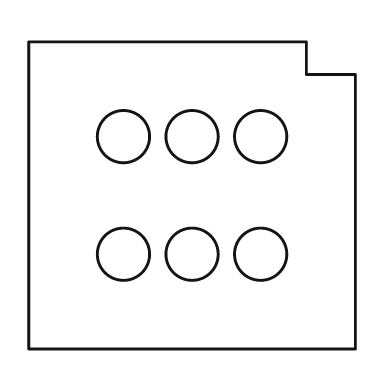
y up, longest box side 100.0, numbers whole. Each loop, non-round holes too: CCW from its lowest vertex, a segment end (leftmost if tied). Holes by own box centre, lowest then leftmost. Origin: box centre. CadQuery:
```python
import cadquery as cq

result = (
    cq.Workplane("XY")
    .moveTo(-50.0, -47.0)
    .lineTo(50.0, -47.0)
    .lineTo(50.0, 37.0)
    .lineTo(35.0, 37.0)
    .lineTo(35.0, 47.0)
    .lineTo(-50.0, 47.0)
    .close()
    .moveTo(-21.0, -18.0)
    .circle(8.0)
    .moveTo(0.0, -18.0)
    .circle(8.0)
    .moveTo(21.0, -18.0)
    .circle(8.0)
    .moveTo(-21.0, 18.0)
    .circle(8.0)
    .moveTo(0.0, 18.0)
    .circle(8.0)
    .moveTo(21.0, 18.0)
    .circle(8.0)
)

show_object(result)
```